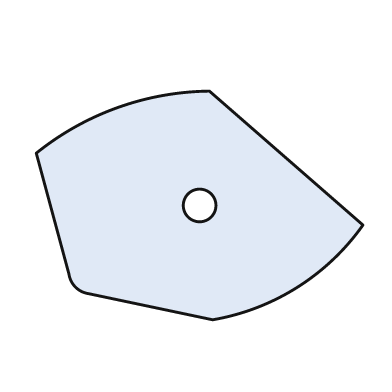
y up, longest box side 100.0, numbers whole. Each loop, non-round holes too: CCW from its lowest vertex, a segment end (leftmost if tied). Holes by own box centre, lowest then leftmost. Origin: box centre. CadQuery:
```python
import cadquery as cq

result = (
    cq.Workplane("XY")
    .moveTo(4.0, -35.0)
    .threePointArc((30.0, -25.0), (50.0, -6.0))
    .lineTo(3.0, 35.0)
    .threePointArc((-25.0, 30.0), (-50.0, 16.0))
    .lineTo(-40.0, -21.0)
    .threePointArc((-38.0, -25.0), (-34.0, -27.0))
    .close()
    .moveTo(0.0, 0.0)
    .circle(5.0)
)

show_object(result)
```